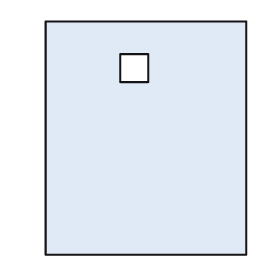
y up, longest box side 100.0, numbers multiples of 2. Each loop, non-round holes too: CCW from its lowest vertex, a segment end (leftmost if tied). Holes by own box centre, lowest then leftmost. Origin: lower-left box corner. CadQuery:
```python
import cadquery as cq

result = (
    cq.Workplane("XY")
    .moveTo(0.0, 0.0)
    .lineTo(86.0, 0.0)
    .lineTo(86.0, 100.0)
    .lineTo(0.0, 100.0)
    .close()
    .moveTo(32.0, 74.0)
    .lineTo(44.0, 74.0)
    .lineTo(44.0, 86.0)
    .lineTo(32.0, 86.0)
    .close()
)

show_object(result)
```